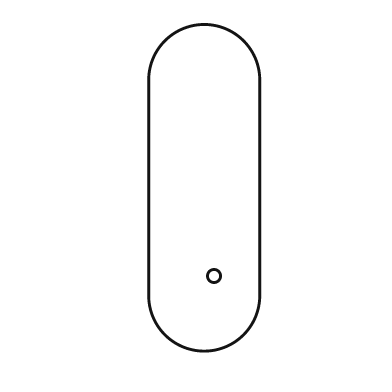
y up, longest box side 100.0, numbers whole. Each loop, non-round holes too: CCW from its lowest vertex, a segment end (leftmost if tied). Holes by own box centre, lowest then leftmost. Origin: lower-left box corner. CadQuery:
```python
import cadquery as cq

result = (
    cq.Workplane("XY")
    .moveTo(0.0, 17.0)
    .threePointArc((17.0, 0.0), (34.0, 17.0))
    .lineTo(34.0, 83.0)
    .threePointArc((17.0, 100.0), (0.0, 83.0))
    .close()
    .moveTo(20.0, 23.0)
    .circle(2.0)
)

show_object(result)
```